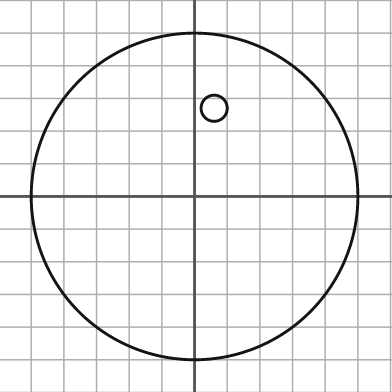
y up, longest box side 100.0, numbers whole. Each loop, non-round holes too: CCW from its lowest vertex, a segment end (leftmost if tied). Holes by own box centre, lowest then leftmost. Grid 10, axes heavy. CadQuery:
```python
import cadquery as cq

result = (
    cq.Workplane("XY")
    .moveTo(0.0, 0.0)
    .circle(50.0)
    .moveTo(6.0, 27.0)
    .circle(4.0)
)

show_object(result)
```